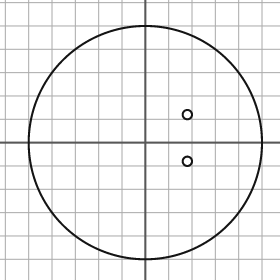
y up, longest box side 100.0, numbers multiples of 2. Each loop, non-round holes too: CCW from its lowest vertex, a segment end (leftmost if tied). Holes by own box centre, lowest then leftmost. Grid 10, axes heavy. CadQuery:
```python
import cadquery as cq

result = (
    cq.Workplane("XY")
    .moveTo(0.0, 0.0)
    .circle(50.0)
    .moveTo(18.0, -8.0)
    .circle(2.0)
    .moveTo(18.0, 12.0)
    .circle(2.0)
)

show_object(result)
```